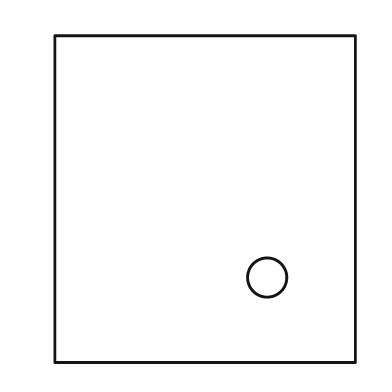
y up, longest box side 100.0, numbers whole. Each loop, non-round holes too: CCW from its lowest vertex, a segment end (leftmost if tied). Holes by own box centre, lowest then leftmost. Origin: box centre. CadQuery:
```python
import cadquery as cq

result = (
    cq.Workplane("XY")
    .moveTo(-46.0, -50.0)
    .lineTo(46.0, -50.0)
    .lineTo(46.0, 50.0)
    .lineTo(-46.0, 50.0)
    .close()
    .moveTo(19.0, -24.0)
    .circle(6.0)
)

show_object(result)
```